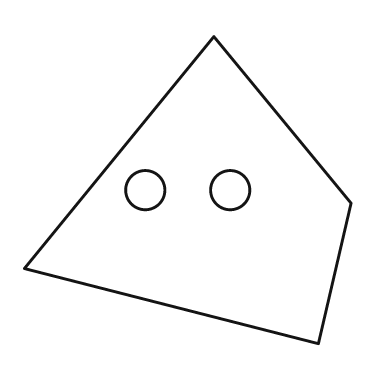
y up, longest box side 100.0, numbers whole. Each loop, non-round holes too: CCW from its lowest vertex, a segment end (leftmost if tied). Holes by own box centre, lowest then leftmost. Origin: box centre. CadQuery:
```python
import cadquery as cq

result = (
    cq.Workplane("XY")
    .moveTo(40.0, -47.0)
    .lineTo(50.0, -4.0)
    .lineTo(8.0, 47.0)
    .lineTo(-50.0, -24.0)
    .close()
    .moveTo(-13.0, 0.0)
    .circle(6.0)
    .moveTo(13.0, 0.0)
    .circle(6.0)
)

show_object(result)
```